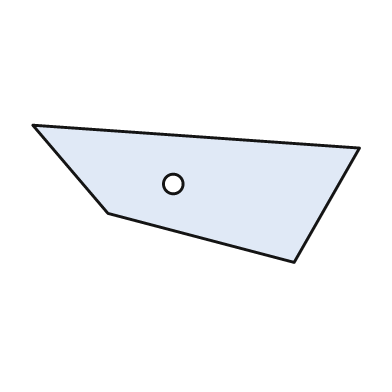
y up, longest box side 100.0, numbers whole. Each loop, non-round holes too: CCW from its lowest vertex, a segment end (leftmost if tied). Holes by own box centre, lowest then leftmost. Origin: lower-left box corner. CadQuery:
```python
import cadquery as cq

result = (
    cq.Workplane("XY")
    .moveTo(80.0, 0.0)
    .lineTo(100.0, 35.0)
    .lineTo(0.0, 42.0)
    .lineTo(23.0, 15.0)
    .close()
    .moveTo(43.0, 24.0)
    .circle(3.0)
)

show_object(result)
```